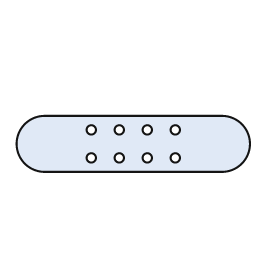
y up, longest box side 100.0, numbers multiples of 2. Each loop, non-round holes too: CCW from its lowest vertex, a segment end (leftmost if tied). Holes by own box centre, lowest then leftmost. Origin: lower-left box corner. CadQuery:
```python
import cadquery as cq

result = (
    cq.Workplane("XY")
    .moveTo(12.0, 0.0)
    .lineTo(88.0, 0.0)
    .threePointArc((100.0, 12.0), (88.0, 24.0))
    .lineTo(12.0, 24.0)
    .threePointArc((0.0, 12.0), (12.0, 0.0))
    .close()
    .moveTo(32.0, 6.0)
    .circle(2.0)
    .moveTo(44.0, 6.0)
    .circle(2.0)
    .moveTo(56.0, 6.0)
    .circle(2.0)
    .moveTo(68.0, 6.0)
    .circle(2.0)
    .moveTo(32.0, 18.0)
    .circle(2.0)
    .moveTo(44.0, 18.0)
    .circle(2.0)
    .moveTo(56.0, 18.0)
    .circle(2.0)
    .moveTo(68.0, 18.0)
    .circle(2.0)
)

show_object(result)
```